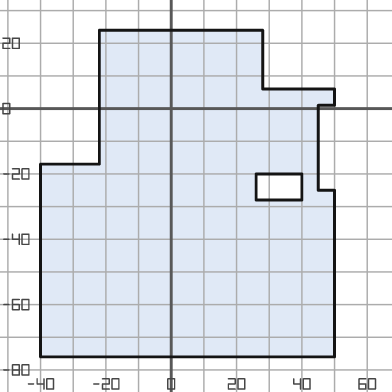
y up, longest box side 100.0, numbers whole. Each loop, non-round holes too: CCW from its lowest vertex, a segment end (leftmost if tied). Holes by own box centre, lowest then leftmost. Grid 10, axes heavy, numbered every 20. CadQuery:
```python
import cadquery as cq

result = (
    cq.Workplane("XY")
    .moveTo(-40.0, -76.0)
    .lineTo(50.0, -76.0)
    .lineTo(50.0, -25.0)
    .lineTo(45.0, -25.0)
    .lineTo(45.0, 1.0)
    .lineTo(50.0, 1.0)
    .lineTo(50.0, 6.0)
    .lineTo(28.0, 6.0)
    .lineTo(28.0, 24.0)
    .lineTo(-22.0, 24.0)
    .lineTo(-22.0, -17.0)
    .lineTo(-40.0, -17.0)
    .close()
    .moveTo(26.0, -28.0)
    .lineTo(40.0, -28.0)
    .lineTo(40.0, -20.0)
    .lineTo(26.0, -20.0)
    .close()
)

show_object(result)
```